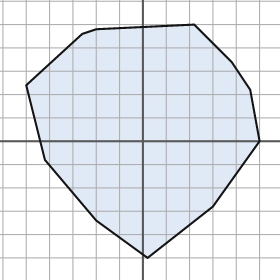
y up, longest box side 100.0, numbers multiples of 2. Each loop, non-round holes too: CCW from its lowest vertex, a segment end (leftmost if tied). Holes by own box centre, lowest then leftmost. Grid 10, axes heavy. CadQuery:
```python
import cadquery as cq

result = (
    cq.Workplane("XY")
    .moveTo(2.0, -50.0)
    .lineTo(30.0, -28.0)
    .lineTo(50.0, 0.0)
    .lineTo(46.0, 22.0)
    .lineTo(38.0, 34.0)
    .lineTo(22.0, 50.0)
    .lineTo(-20.0, 48.0)
    .lineTo(-26.0, 46.0)
    .lineTo(-50.0, 24.0)
    .lineTo(-42.0, -8.0)
    .lineTo(-20.0, -34.0)
    .close()
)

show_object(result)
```